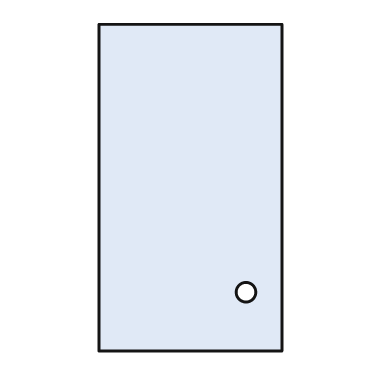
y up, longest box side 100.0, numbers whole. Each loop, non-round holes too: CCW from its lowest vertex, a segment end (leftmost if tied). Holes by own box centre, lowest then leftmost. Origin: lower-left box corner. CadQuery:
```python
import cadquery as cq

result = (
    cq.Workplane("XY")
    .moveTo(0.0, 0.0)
    .lineTo(56.0, 0.0)
    .lineTo(56.0, 100.0)
    .lineTo(0.0, 100.0)
    .close()
    .moveTo(45.0, 18.0)
    .circle(3.0)
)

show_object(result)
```